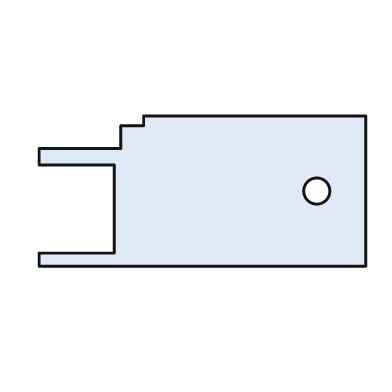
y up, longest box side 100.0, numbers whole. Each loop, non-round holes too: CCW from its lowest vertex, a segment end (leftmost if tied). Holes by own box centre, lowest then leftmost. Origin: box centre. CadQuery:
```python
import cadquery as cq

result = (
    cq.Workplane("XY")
    .moveTo(-50.0, -23.0)
    .lineTo(50.0, -23.0)
    .lineTo(50.0, 23.0)
    .lineTo(-18.0, 23.0)
    .lineTo(-18.0, 20.0)
    .lineTo(-25.0, 20.0)
    .lineTo(-25.0, 13.0)
    .lineTo(-50.0, 13.0)
    .lineTo(-50.0, 8.0)
    .lineTo(-27.0, 8.0)
    .lineTo(-27.0, -19.0)
    .lineTo(-50.0, -19.0)
    .close()
    .moveTo(35.0, 0.0)
    .circle(4.0)
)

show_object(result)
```